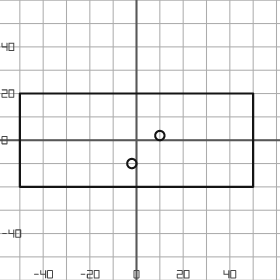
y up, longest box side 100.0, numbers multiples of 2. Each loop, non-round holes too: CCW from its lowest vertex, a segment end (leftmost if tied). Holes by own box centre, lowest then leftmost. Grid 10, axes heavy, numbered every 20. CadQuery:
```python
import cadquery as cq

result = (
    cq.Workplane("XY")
    .moveTo(-50.0, -20.0)
    .lineTo(50.0, -20.0)
    .lineTo(50.0, 20.0)
    .lineTo(-50.0, 20.0)
    .close()
    .moveTo(-2.0, -10.0)
    .circle(2.0)
    .moveTo(10.0, 2.0)
    .circle(2.0)
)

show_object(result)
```